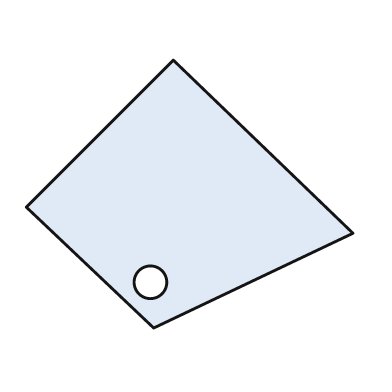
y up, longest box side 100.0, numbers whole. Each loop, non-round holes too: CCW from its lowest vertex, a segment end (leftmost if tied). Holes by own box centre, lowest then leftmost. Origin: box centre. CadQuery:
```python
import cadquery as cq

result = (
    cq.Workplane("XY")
    .moveTo(-11.0, -41.0)
    .lineTo(50.0, -12.0)
    .lineTo(-5.0, 41.0)
    .lineTo(-50.0, -4.0)
    .close()
    .moveTo(-12.0, -27.0)
    .circle(5.0)
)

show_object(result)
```